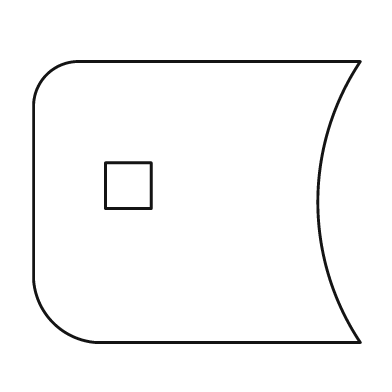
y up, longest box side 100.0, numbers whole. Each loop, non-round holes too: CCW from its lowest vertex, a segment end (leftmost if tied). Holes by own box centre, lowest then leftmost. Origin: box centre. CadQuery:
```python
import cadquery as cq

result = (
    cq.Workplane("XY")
    .moveTo(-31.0, -43.0)
    .lineTo(50.0, -43.0)
    .threePointArc((37.0, 0.0), (50.0, 43.0))
    .lineTo(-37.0, 43.0)
    .threePointArc((-46.0, 39.0), (-50.0, 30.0))
    .lineTo(-50.0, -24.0)
    .threePointArc((-44.0, -37.0), (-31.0, -43.0))
    .close()
    .moveTo(-28.0, -2.0)
    .lineTo(-14.0, -2.0)
    .lineTo(-14.0, 12.0)
    .lineTo(-28.0, 12.0)
    .close()
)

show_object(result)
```